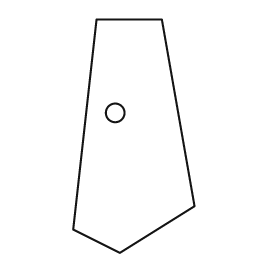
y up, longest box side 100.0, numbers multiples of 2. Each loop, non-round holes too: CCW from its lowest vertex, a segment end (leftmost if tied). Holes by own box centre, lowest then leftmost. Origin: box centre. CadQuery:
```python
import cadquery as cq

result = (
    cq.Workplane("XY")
    .moveTo(-6.0, -50.0)
    .lineTo(26.0, -30.0)
    .lineTo(12.0, 50.0)
    .lineTo(-16.0, 50.0)
    .lineTo(-26.0, -40.0)
    .close()
    .moveTo(-8.0, 10.0)
    .circle(4.0)
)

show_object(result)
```